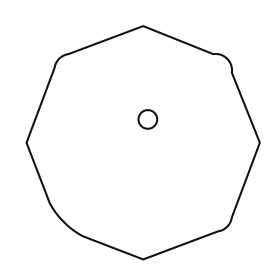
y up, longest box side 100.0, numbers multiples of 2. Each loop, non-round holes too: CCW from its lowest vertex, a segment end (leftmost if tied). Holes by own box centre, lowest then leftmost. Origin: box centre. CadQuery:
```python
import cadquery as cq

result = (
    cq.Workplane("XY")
    .moveTo(0.0, -50.0)
    .lineTo(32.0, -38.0)
    .threePointArc((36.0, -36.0), (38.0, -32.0))
    .lineTo(50.0, 0.0)
    .lineTo(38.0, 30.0)
    .threePointArc((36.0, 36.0), (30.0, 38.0))
    .lineTo(0.0, 50.0)
    .lineTo(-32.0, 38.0)
    .threePointArc((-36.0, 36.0), (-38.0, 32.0))
    .lineTo(-50.0, 0.0)
    .lineTo(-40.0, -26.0)
    .threePointArc((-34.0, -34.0), (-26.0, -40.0))
    .close()
    .moveTo(2.0, 10.0)
    .circle(4.0)
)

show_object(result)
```